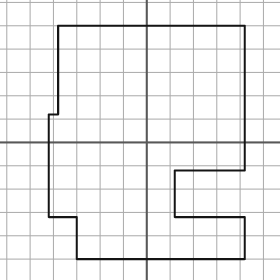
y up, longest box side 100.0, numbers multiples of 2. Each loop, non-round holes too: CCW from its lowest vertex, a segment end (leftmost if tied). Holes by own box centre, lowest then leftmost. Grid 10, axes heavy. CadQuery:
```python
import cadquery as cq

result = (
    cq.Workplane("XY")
    .moveTo(-30.0, -50.0)
    .lineTo(42.0, -50.0)
    .lineTo(42.0, -32.0)
    .lineTo(12.0, -32.0)
    .lineTo(12.0, -12.0)
    .lineTo(42.0, -12.0)
    .lineTo(42.0, 50.0)
    .lineTo(-38.0, 50.0)
    .lineTo(-38.0, 12.0)
    .lineTo(-42.0, 12.0)
    .lineTo(-42.0, -32.0)
    .lineTo(-30.0, -32.0)
    .close()
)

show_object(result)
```